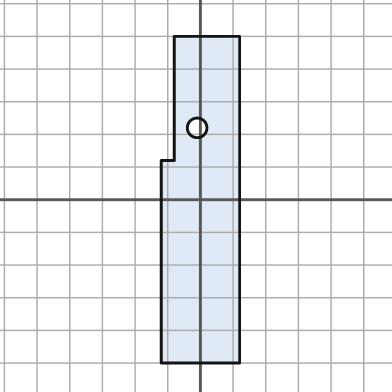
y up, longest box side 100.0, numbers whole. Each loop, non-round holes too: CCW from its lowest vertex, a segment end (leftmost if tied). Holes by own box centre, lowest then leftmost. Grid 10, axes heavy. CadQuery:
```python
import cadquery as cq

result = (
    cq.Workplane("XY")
    .moveTo(-12.0, -50.0)
    .lineTo(12.0, -50.0)
    .lineTo(12.0, 50.0)
    .lineTo(-8.0, 50.0)
    .lineTo(-8.0, 12.0)
    .lineTo(-12.0, 12.0)
    .close()
    .moveTo(-1.0, 22.0)
    .circle(3.0)
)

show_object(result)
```